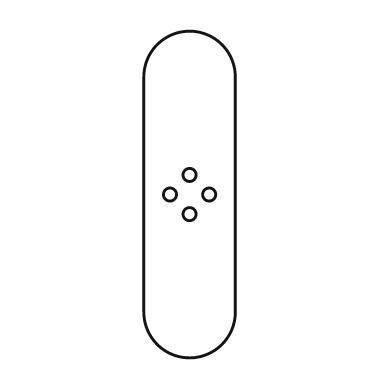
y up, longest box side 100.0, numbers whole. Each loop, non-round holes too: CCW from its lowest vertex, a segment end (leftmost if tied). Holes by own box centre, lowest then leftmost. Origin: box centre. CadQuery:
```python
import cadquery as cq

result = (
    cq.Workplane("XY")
    .moveTo(-14.0, -36.0)
    .threePointArc((0.0, -50.0), (14.0, -36.0))
    .lineTo(14.0, 36.0)
    .threePointArc((0.0, 50.0), (-14.0, 36.0))
    .close()
    .moveTo(0.0, -6.0)
    .circle(2.0)
    .moveTo(-6.0, 0.0)
    .circle(2.0)
    .moveTo(6.0, 0.0)
    .circle(2.0)
    .moveTo(0.0, 6.0)
    .circle(2.0)
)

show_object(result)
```